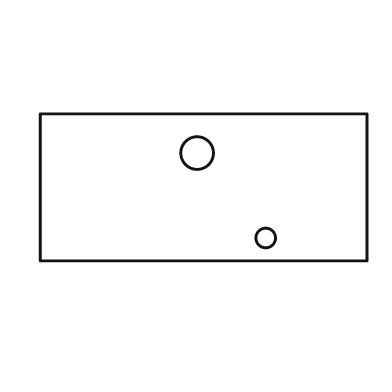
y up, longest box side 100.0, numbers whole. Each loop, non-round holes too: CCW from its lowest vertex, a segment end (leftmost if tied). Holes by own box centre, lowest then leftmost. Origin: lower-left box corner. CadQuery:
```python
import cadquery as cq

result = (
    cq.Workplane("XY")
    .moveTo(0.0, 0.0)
    .lineTo(100.0, 0.0)
    .lineTo(100.0, 45.0)
    .lineTo(0.0, 45.0)
    .close()
    .moveTo(69.0, 7.0)
    .circle(3.0)
    .moveTo(48.0, 33.0)
    .circle(5.0)
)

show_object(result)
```